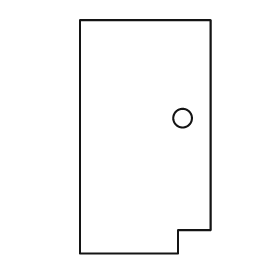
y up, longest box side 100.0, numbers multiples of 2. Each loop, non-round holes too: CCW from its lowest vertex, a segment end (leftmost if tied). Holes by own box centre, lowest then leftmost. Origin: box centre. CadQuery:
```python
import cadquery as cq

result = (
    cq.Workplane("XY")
    .moveTo(-28.0, -50.0)
    .lineTo(14.0, -50.0)
    .lineTo(14.0, -40.0)
    .lineTo(28.0, -40.0)
    .lineTo(28.0, 50.0)
    .lineTo(-28.0, 50.0)
    .close()
    .moveTo(16.0, 8.0)
    .circle(4.0)
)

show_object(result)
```